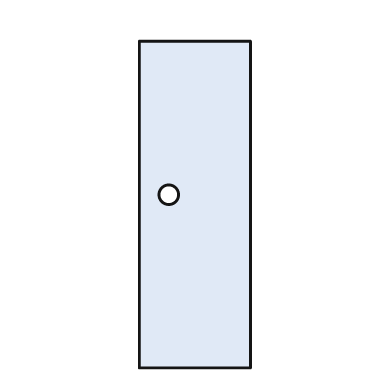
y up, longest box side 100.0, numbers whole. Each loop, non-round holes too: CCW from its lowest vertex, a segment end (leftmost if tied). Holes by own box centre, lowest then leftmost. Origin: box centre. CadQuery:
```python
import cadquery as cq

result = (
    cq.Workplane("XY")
    .moveTo(-17.0, -50.0)
    .lineTo(17.0, -50.0)
    .lineTo(17.0, 50.0)
    .lineTo(-17.0, 50.0)
    .close()
    .moveTo(-8.0, 3.0)
    .circle(3.0)
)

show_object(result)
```